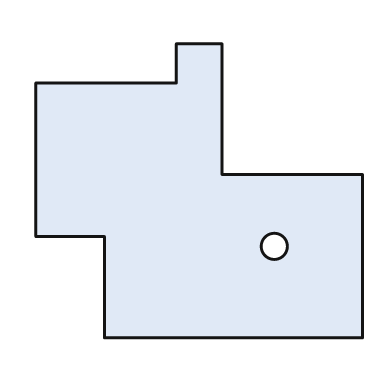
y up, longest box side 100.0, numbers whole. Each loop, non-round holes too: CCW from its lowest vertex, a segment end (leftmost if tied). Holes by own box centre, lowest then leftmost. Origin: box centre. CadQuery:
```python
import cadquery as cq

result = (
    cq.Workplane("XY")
    .moveTo(-29.0, -45.0)
    .lineTo(50.0, -45.0)
    .lineTo(50.0, 5.0)
    .lineTo(7.0, 5.0)
    .lineTo(7.0, 45.0)
    .lineTo(-7.0, 45.0)
    .lineTo(-7.0, 33.0)
    .lineTo(-50.0, 33.0)
    .lineTo(-50.0, -14.0)
    .lineTo(-29.0, -14.0)
    .close()
    .moveTo(23.0, -17.0)
    .circle(4.0)
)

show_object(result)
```